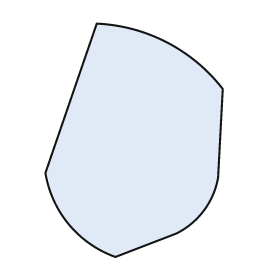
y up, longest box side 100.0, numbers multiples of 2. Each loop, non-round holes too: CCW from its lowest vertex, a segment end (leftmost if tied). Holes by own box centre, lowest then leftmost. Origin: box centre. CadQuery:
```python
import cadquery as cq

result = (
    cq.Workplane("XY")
    .moveTo(-8.0, -50.0)
    .lineTo(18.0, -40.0)
    .threePointArc((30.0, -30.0), (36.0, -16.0))
    .lineTo(38.0, 22.0)
    .threePointArc((14.0, 42.0), (-16.0, 50.0))
    .lineTo(-38.0, -14.0)
    .threePointArc((-28.0, -36.0), (-8.0, -50.0))
    .close()
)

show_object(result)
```